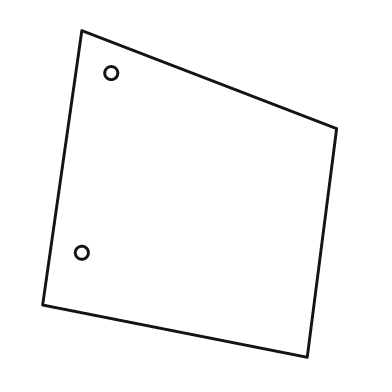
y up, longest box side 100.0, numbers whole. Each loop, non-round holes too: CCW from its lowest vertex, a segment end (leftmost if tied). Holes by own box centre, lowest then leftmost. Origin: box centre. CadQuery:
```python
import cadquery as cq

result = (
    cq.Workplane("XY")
    .moveTo(36.0, -50.0)
    .lineTo(45.0, 20.0)
    .lineTo(-33.0, 50.0)
    .lineTo(-45.0, -34.0)
    .close()
    .moveTo(-33.0, -18.0)
    .circle(2.0)
    .moveTo(-24.0, 37.0)
    .circle(2.0)
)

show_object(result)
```